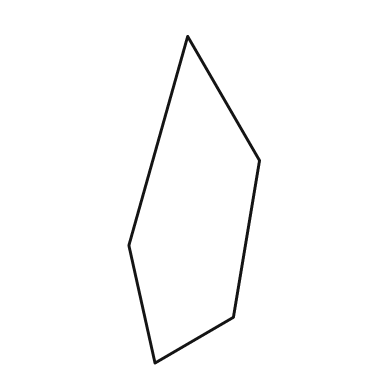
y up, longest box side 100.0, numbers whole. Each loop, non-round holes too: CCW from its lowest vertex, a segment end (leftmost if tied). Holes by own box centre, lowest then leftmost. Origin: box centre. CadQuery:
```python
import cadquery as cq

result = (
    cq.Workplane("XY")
    .moveTo(-12.0, -50.0)
    .lineTo(12.0, -36.0)
    .lineTo(20.0, 12.0)
    .lineTo(-2.0, 50.0)
    .lineTo(-20.0, -14.0)
    .close()
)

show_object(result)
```